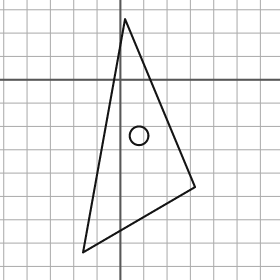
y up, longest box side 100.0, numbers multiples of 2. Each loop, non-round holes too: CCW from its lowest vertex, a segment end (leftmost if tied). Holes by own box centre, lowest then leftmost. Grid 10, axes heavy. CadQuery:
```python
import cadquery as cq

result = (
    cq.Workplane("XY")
    .moveTo(-16.0, -74.0)
    .lineTo(32.0, -46.0)
    .lineTo(2.0, 26.0)
    .close()
    .moveTo(8.0, -24.0)
    .circle(4.0)
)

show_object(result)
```